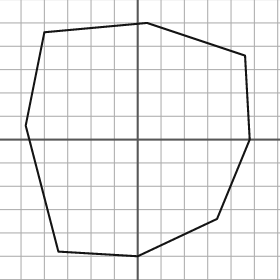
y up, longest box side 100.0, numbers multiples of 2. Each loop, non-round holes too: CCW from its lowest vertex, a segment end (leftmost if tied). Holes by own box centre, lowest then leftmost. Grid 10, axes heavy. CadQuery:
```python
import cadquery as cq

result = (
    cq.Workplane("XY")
    .moveTo(0.0, -50.0)
    .lineTo(34.0, -34.0)
    .lineTo(48.0, 0.0)
    .lineTo(46.0, 36.0)
    .lineTo(4.0, 50.0)
    .lineTo(-40.0, 46.0)
    .lineTo(-48.0, 6.0)
    .lineTo(-34.0, -48.0)
    .close()
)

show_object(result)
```